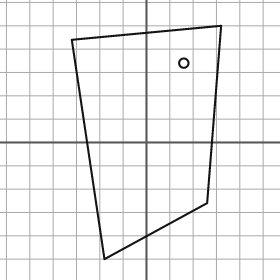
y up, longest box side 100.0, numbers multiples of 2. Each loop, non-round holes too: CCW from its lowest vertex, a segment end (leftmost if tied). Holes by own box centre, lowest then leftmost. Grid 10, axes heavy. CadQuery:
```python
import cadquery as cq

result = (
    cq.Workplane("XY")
    .moveTo(-18.0, -50.0)
    .lineTo(26.0, -26.0)
    .lineTo(32.0, 50.0)
    .lineTo(-32.0, 44.0)
    .close()
    .moveTo(16.0, 34.0)
    .circle(2.0)
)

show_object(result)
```